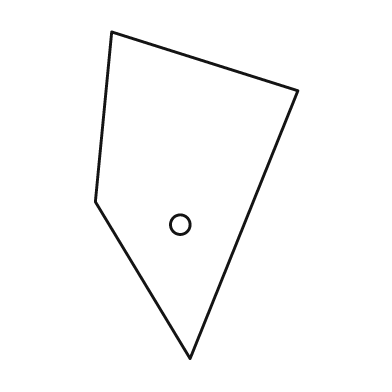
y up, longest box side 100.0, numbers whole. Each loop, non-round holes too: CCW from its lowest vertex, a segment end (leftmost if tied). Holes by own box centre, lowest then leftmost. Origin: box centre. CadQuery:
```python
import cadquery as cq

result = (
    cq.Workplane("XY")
    .moveTo(-2.0, -50.0)
    .lineTo(31.0, 32.0)
    .lineTo(-26.0, 50.0)
    .lineTo(-31.0, -2.0)
    .close()
    .moveTo(-5.0, -9.0)
    .circle(3.0)
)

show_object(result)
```